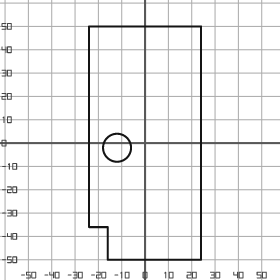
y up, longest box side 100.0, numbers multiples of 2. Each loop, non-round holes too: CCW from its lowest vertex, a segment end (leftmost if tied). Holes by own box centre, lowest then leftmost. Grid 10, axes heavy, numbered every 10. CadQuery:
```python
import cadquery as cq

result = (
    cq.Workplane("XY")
    .moveTo(-16.0, -50.0)
    .lineTo(24.0, -50.0)
    .lineTo(24.0, 50.0)
    .lineTo(-24.0, 50.0)
    .lineTo(-24.0, -36.0)
    .lineTo(-16.0, -36.0)
    .close()
    .moveTo(-12.0, -2.0)
    .circle(6.0)
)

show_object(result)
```